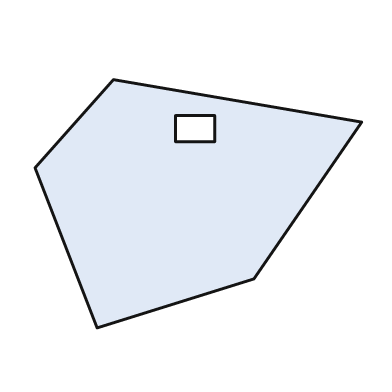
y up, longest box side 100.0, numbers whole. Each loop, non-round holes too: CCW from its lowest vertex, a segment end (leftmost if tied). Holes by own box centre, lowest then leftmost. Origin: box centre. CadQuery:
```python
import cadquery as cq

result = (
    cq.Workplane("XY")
    .moveTo(-31.0, -38.0)
    .lineTo(17.0, -23.0)
    .lineTo(50.0, 25.0)
    .lineTo(-26.0, 38.0)
    .lineTo(-50.0, 11.0)
    .close()
    .moveTo(-7.0, 19.0)
    .lineTo(5.0, 19.0)
    .lineTo(5.0, 27.0)
    .lineTo(-7.0, 27.0)
    .close()
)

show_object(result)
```